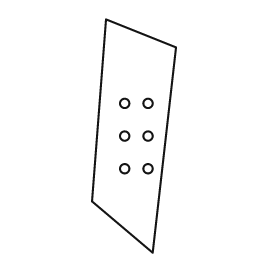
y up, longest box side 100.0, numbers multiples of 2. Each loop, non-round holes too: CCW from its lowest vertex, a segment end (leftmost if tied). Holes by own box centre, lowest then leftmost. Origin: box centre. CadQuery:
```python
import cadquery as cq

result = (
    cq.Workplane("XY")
    .moveTo(8.0, -50.0)
    .lineTo(18.0, 38.0)
    .lineTo(-12.0, 50.0)
    .lineTo(-18.0, -28.0)
    .close()
    .moveTo(-4.0, -14.0)
    .circle(2.0)
    .moveTo(6.0, -14.0)
    .circle(2.0)
    .moveTo(-4.0, 0.0)
    .circle(2.0)
    .moveTo(6.0, 0.0)
    .circle(2.0)
    .moveTo(-4.0, 14.0)
    .circle(2.0)
    .moveTo(6.0, 14.0)
    .circle(2.0)
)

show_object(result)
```